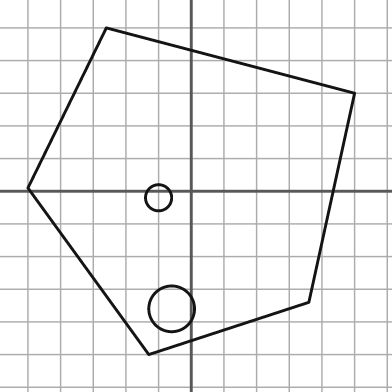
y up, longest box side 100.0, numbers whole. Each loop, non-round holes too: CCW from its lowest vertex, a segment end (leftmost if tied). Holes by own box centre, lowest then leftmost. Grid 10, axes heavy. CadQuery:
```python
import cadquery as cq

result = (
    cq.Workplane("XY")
    .moveTo(-13.0, -50.0)
    .lineTo(36.0, -34.0)
    .lineTo(50.0, 30.0)
    .lineTo(-26.0, 50.0)
    .lineTo(-50.0, 1.0)
    .close()
    .moveTo(-6.0, -36.0)
    .circle(7.0)
    .moveTo(-10.0, -2.0)
    .circle(4.0)
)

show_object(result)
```